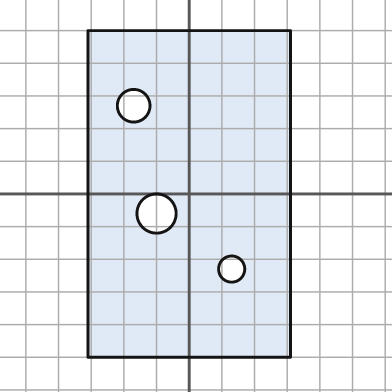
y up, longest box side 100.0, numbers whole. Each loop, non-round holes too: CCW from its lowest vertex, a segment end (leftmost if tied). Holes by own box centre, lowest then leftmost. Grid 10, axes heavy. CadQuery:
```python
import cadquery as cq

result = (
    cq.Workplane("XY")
    .moveTo(-31.0, -50.0)
    .lineTo(31.0, -50.0)
    .lineTo(31.0, 50.0)
    .lineTo(-31.0, 50.0)
    .close()
    .moveTo(13.0, -23.0)
    .circle(4.0)
    .moveTo(-10.0, -6.0)
    .circle(6.0)
    .moveTo(-17.0, 27.0)
    .circle(5.0)
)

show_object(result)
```